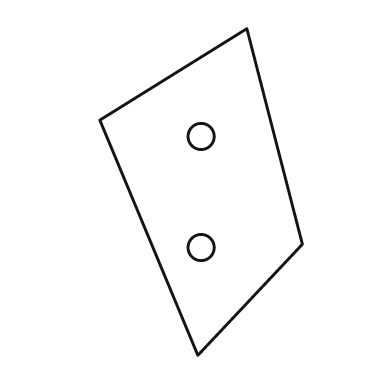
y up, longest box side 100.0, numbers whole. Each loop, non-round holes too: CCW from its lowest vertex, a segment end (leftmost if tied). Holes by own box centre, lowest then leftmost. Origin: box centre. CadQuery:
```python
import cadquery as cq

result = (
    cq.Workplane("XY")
    .moveTo(-1.0, -50.0)
    .lineTo(31.0, -16.0)
    .lineTo(14.0, 50.0)
    .lineTo(-31.0, 22.0)
    .close()
    .moveTo(0.0, -17.0)
    .circle(4.0)
    .moveTo(0.0, 17.0)
    .circle(4.0)
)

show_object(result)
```